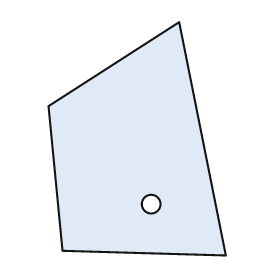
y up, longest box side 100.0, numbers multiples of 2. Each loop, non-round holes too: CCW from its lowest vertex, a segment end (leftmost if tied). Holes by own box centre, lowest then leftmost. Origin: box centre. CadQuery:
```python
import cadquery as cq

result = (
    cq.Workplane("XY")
    .moveTo(38.0, -50.0)
    .lineTo(18.0, 50.0)
    .lineTo(-38.0, 14.0)
    .lineTo(-32.0, -48.0)
    .close()
    .moveTo(6.0, -28.0)
    .circle(4.0)
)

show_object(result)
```